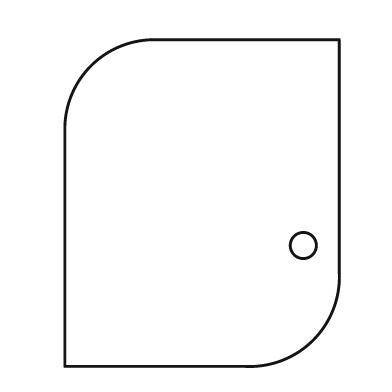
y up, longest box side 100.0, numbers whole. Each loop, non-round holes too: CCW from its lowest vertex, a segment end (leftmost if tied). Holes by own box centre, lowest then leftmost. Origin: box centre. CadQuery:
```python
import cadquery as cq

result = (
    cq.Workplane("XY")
    .moveTo(-42.0, -50.0)
    .lineTo(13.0, -50.0)
    .threePointArc((34.0, -42.0), (42.0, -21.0))
    .lineTo(42.0, 50.0)
    .lineTo(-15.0, 50.0)
    .threePointArc((-34.0, 42.0), (-42.0, 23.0))
    .close()
    .moveTo(31.0, -13.0)
    .circle(4.0)
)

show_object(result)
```